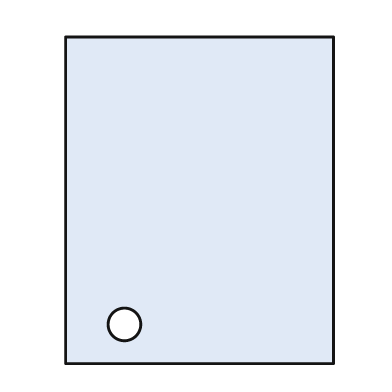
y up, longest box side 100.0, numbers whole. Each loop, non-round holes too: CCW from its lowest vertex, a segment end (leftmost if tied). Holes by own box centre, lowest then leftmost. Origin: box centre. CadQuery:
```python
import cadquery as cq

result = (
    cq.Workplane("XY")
    .moveTo(-41.0, -50.0)
    .lineTo(41.0, -50.0)
    .lineTo(41.0, 50.0)
    .lineTo(-41.0, 50.0)
    .close()
    .moveTo(-23.0, -38.0)
    .circle(5.0)
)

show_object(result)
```